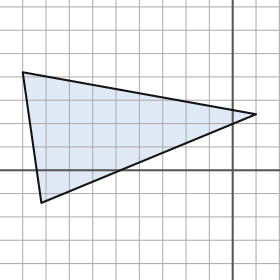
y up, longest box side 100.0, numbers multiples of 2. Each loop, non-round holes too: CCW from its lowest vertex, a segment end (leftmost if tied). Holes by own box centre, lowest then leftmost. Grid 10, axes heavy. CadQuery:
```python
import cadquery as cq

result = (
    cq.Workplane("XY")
    .moveTo(-82.0, -14.0)
    .lineTo(10.0, 24.0)
    .lineTo(-90.0, 42.0)
    .close()
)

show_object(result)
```